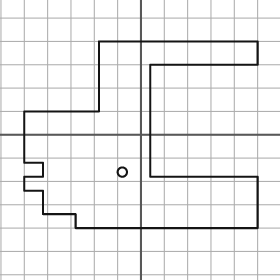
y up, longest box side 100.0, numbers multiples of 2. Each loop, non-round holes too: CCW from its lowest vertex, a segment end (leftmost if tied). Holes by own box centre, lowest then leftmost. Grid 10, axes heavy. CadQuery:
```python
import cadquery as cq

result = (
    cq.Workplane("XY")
    .moveTo(-28.0, -40.0)
    .lineTo(50.0, -40.0)
    .lineTo(50.0, -18.0)
    .lineTo(4.0, -18.0)
    .lineTo(4.0, 30.0)
    .lineTo(50.0, 30.0)
    .lineTo(50.0, 40.0)
    .lineTo(-18.0, 40.0)
    .lineTo(-18.0, 10.0)
    .lineTo(-50.0, 10.0)
    .lineTo(-50.0, -12.0)
    .lineTo(-42.0, -12.0)
    .lineTo(-42.0, -18.0)
    .lineTo(-50.0, -18.0)
    .lineTo(-50.0, -24.0)
    .lineTo(-42.0, -24.0)
    .lineTo(-42.0, -34.0)
    .lineTo(-28.0, -34.0)
    .close()
    .moveTo(-8.0, -16.0)
    .circle(2.0)
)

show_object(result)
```